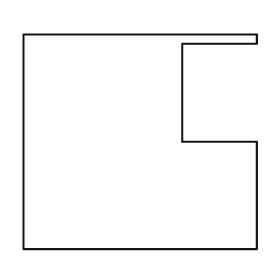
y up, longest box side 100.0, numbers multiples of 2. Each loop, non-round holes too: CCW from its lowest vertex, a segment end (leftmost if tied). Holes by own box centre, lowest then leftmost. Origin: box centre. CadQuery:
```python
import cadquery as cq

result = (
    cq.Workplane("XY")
    .moveTo(-50.0, -46.0)
    .lineTo(50.0, -46.0)
    .lineTo(50.0, 0.0)
    .lineTo(18.0, 0.0)
    .lineTo(18.0, 42.0)
    .lineTo(50.0, 42.0)
    .lineTo(50.0, 46.0)
    .lineTo(-50.0, 46.0)
    .close()
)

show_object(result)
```